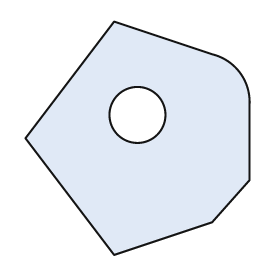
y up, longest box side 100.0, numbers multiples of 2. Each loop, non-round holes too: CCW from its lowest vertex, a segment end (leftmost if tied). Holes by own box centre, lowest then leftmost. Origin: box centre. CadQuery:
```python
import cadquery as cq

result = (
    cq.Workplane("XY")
    .moveTo(-10.0, -50.0)
    .lineTo(32.0, -36.0)
    .lineTo(48.0, -18.0)
    .lineTo(48.0, 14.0)
    .threePointArc((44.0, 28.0), (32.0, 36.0))
    .lineTo(-10.0, 50.0)
    .lineTo(-48.0, 0.0)
    .close()
    .moveTo(0.0, 10.0)
    .circle(12.0)
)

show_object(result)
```